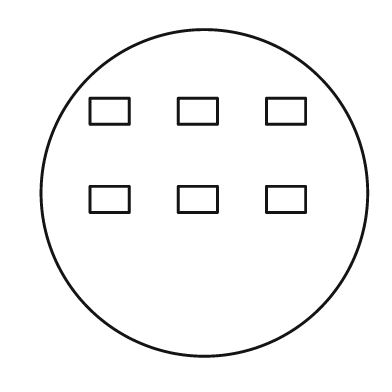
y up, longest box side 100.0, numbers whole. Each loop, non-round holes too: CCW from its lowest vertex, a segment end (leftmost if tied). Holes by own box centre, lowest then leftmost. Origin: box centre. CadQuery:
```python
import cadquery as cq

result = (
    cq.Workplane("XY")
    .moveTo(0.0, 0.0)
    .circle(50.0)
    .moveTo(-35.0, -6.0)
    .lineTo(-23.0, -6.0)
    .lineTo(-23.0, 2.0)
    .lineTo(-35.0, 2.0)
    .close()
    .moveTo(-8.0, -6.0)
    .lineTo(4.0, -6.0)
    .lineTo(4.0, 2.0)
    .lineTo(-8.0, 2.0)
    .close()
    .moveTo(19.0, -6.0)
    .lineTo(31.0, -6.0)
    .lineTo(31.0, 2.0)
    .lineTo(19.0, 2.0)
    .close()
    .moveTo(-35.0, 21.0)
    .lineTo(-23.0, 21.0)
    .lineTo(-23.0, 29.0)
    .lineTo(-35.0, 29.0)
    .close()
    .moveTo(-8.0, 21.0)
    .lineTo(4.0, 21.0)
    .lineTo(4.0, 29.0)
    .lineTo(-8.0, 29.0)
    .close()
    .moveTo(19.0, 21.0)
    .lineTo(31.0, 21.0)
    .lineTo(31.0, 29.0)
    .lineTo(19.0, 29.0)
    .close()
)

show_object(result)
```